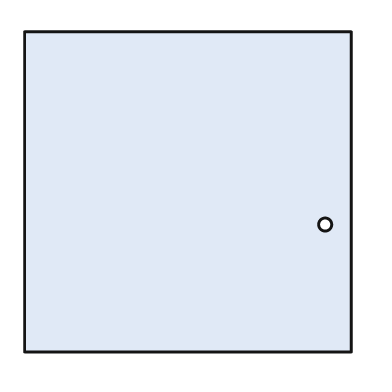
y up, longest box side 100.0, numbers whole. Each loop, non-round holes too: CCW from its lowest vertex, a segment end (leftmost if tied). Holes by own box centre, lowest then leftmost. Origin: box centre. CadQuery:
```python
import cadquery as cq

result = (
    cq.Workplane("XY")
    .moveTo(-50.0, -49.0)
    .lineTo(50.0, -49.0)
    .lineTo(50.0, 49.0)
    .lineTo(-50.0, 49.0)
    .close()
    .moveTo(42.0, -10.0)
    .circle(2.0)
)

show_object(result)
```